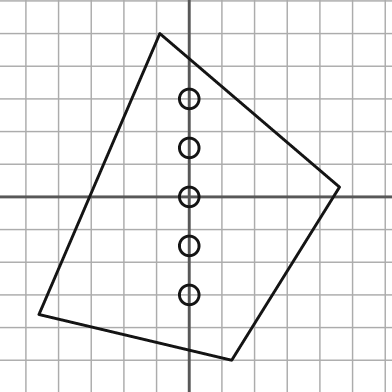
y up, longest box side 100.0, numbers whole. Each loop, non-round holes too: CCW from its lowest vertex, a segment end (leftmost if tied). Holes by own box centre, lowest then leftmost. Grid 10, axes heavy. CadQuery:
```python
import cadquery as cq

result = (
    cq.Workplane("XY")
    .moveTo(13.0, -50.0)
    .lineTo(46.0, 3.0)
    .lineTo(-9.0, 50.0)
    .lineTo(-46.0, -36.0)
    .close()
    .moveTo(0.0, -30.0)
    .circle(3.0)
    .moveTo(0.0, -15.0)
    .circle(3.0)
    .moveTo(0.0, 0.0)
    .circle(3.0)
    .moveTo(0.0, 15.0)
    .circle(3.0)
    .moveTo(0.0, 30.0)
    .circle(3.0)
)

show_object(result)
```